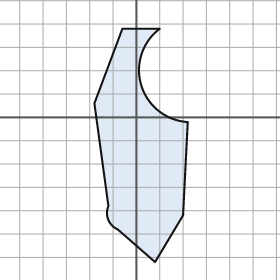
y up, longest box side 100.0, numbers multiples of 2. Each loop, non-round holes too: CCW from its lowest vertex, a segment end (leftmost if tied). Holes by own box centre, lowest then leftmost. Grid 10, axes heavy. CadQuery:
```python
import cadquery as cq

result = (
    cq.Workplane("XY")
    .moveTo(8.0, -62.0)
    .lineTo(20.0, -42.0)
    .lineTo(22.0, -2.0)
    .threePointArc((2.0, 14.0), (10.0, 38.0))
    .lineTo(-6.0, 38.0)
    .lineTo(-18.0, 6.0)
    .lineTo(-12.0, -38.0)
    .threePointArc((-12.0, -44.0), (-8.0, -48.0))
    .close()
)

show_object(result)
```